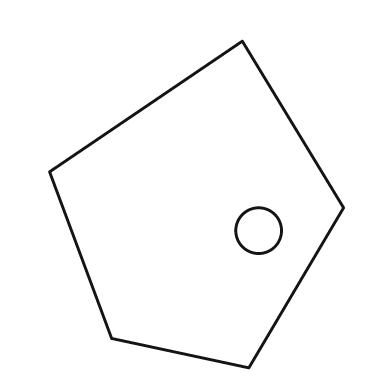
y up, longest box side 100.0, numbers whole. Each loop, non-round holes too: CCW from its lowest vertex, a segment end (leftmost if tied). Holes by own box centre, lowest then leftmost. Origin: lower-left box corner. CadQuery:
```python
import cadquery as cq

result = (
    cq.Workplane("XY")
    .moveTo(61.0, 0.0)
    .lineTo(90.0, 49.0)
    .lineTo(59.0, 100.0)
    .lineTo(0.0, 60.0)
    .lineTo(19.0, 9.0)
    .close()
    .moveTo(64.0, 42.0)
    .circle(7.0)
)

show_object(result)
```